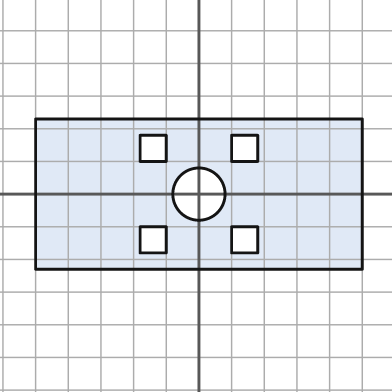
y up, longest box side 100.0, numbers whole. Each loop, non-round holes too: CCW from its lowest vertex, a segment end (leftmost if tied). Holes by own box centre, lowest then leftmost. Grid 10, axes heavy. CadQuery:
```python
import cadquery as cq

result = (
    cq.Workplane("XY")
    .moveTo(-50.0, -23.0)
    .lineTo(50.0, -23.0)
    .lineTo(50.0, 23.0)
    .lineTo(-50.0, 23.0)
    .close()
    .moveTo(-18.0, -18.0)
    .lineTo(-10.0, -18.0)
    .lineTo(-10.0, -10.0)
    .lineTo(-18.0, -10.0)
    .close()
    .moveTo(10.0, -18.0)
    .lineTo(18.0, -18.0)
    .lineTo(18.0, -10.0)
    .lineTo(10.0, -10.0)
    .close()
    .moveTo(0.0, 0.0)
    .circle(8.0)
    .moveTo(-18.0, 10.0)
    .lineTo(-10.0, 10.0)
    .lineTo(-10.0, 18.0)
    .lineTo(-18.0, 18.0)
    .close()
    .moveTo(10.0, 10.0)
    .lineTo(18.0, 10.0)
    .lineTo(18.0, 18.0)
    .lineTo(10.0, 18.0)
    .close()
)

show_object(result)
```